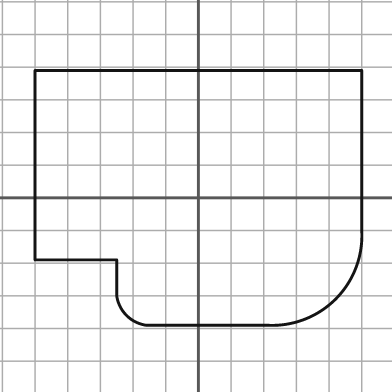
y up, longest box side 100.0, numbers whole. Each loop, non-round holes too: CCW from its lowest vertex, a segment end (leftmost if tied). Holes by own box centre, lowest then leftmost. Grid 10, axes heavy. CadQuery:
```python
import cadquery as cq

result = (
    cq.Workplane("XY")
    .moveTo(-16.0, -39.0)
    .lineTo(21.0, -39.0)
    .threePointArc((42.0, -31.0), (50.0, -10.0))
    .lineTo(50.0, 39.0)
    .lineTo(-50.0, 39.0)
    .lineTo(-50.0, -19.0)
    .lineTo(-25.0, -19.0)
    .lineTo(-25.0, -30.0)
    .threePointArc((-22.0, -36.0), (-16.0, -39.0))
    .close()
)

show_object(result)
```